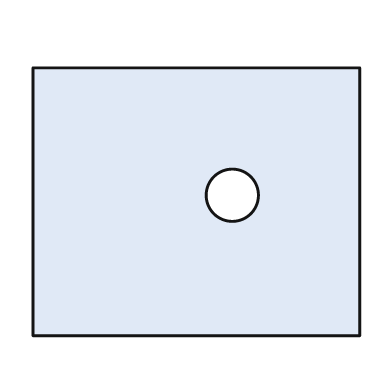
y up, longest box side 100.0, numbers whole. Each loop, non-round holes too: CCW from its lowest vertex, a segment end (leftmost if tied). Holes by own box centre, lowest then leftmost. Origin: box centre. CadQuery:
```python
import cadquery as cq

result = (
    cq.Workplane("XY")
    .moveTo(-50.0, -41.0)
    .lineTo(50.0, -41.0)
    .lineTo(50.0, 41.0)
    .lineTo(-50.0, 41.0)
    .close()
    .moveTo(11.0, 2.0)
    .circle(8.0)
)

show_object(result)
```